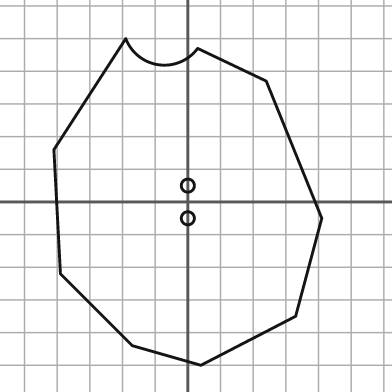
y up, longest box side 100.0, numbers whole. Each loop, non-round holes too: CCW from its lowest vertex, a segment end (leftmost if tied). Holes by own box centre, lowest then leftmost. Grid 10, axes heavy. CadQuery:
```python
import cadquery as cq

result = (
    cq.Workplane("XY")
    .moveTo(4.0, -50.0)
    .lineTo(33.0, -35.0)
    .lineTo(41.0, -5.0)
    .lineTo(24.0, 37.0)
    .lineTo(3.0, 47.0)
    .threePointArc((-9.0, 42.0), (-19.0, 50.0))
    .lineTo(-41.0, 16.0)
    .lineTo(-39.0, -22.0)
    .lineTo(-17.0, -44.0)
    .close()
    .moveTo(0.0, -5.0)
    .circle(2.0)
    .moveTo(0.0, 5.0)
    .circle(2.0)
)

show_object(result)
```